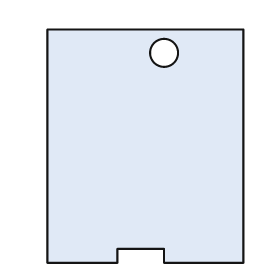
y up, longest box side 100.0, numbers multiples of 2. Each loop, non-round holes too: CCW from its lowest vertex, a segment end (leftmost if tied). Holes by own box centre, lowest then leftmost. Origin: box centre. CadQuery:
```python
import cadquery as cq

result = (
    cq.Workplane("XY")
    .moveTo(-42.0, -50.0)
    .lineTo(-12.0, -50.0)
    .lineTo(-12.0, -44.0)
    .lineTo(8.0, -44.0)
    .lineTo(8.0, -50.0)
    .lineTo(42.0, -50.0)
    .lineTo(42.0, 50.0)
    .lineTo(-42.0, 50.0)
    .close()
    .moveTo(8.0, 40.0)
    .circle(6.0)
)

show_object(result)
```